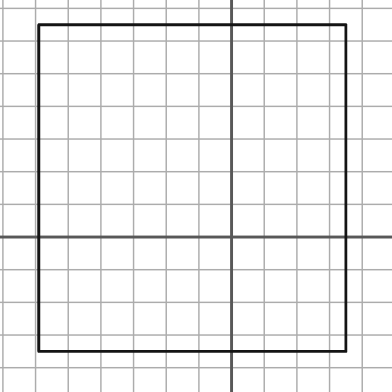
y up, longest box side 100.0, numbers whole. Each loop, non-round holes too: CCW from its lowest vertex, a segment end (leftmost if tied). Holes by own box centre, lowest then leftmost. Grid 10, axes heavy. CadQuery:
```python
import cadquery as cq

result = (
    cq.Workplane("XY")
    .moveTo(-59.0, -35.0)
    .lineTo(35.0, -35.0)
    .lineTo(35.0, 65.0)
    .lineTo(-59.0, 65.0)
    .close()
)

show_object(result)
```